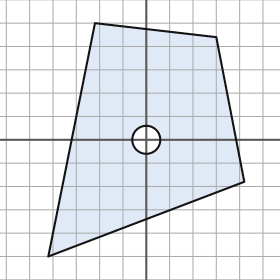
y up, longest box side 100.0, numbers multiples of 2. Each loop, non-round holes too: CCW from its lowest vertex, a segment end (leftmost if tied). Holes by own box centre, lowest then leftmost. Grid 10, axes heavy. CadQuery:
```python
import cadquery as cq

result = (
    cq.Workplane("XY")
    .moveTo(-42.0, -50.0)
    .lineTo(42.0, -18.0)
    .lineTo(30.0, 44.0)
    .lineTo(-22.0, 50.0)
    .close()
    .moveTo(0.0, 0.0)
    .circle(6.0)
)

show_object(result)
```